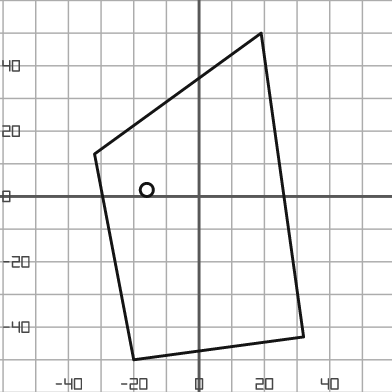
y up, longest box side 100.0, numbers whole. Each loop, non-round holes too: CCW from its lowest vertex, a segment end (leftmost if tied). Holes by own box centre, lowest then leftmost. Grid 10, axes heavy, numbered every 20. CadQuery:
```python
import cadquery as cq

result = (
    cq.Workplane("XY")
    .moveTo(-20.0, -50.0)
    .lineTo(32.0, -43.0)
    .lineTo(19.0, 50.0)
    .lineTo(-32.0, 13.0)
    .close()
    .moveTo(-16.0, 2.0)
    .circle(2.0)
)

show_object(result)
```